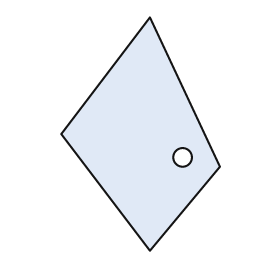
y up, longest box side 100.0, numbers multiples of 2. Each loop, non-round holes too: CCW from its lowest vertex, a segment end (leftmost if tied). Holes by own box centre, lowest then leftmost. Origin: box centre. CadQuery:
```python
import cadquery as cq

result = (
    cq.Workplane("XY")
    .moveTo(4.0, -50.0)
    .lineTo(34.0, -14.0)
    .lineTo(4.0, 50.0)
    .lineTo(-34.0, 0.0)
    .close()
    .moveTo(18.0, -10.0)
    .circle(4.0)
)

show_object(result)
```